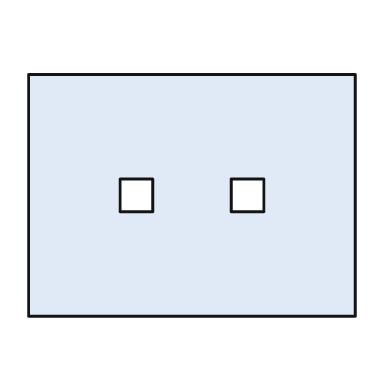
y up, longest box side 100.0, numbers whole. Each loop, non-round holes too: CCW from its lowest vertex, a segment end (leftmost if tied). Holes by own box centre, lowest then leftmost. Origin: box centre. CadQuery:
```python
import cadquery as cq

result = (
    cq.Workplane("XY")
    .moveTo(-50.0, -37.0)
    .lineTo(50.0, -37.0)
    .lineTo(50.0, 37.0)
    .lineTo(-50.0, 37.0)
    .close()
    .moveTo(-22.0, -5.0)
    .lineTo(-12.0, -5.0)
    .lineTo(-12.0, 5.0)
    .lineTo(-22.0, 5.0)
    .close()
    .moveTo(12.0, -5.0)
    .lineTo(22.0, -5.0)
    .lineTo(22.0, 5.0)
    .lineTo(12.0, 5.0)
    .close()
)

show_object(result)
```